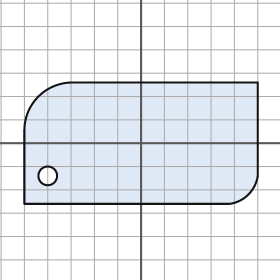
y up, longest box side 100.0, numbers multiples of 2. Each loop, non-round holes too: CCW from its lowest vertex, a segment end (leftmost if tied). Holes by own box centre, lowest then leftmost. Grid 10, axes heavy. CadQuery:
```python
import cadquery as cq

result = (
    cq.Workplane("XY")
    .moveTo(-50.0, -26.0)
    .lineTo(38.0, -26.0)
    .threePointArc((46.0, -22.0), (50.0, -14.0))
    .lineTo(50.0, 26.0)
    .lineTo(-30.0, 26.0)
    .threePointArc((-44.0, 20.0), (-50.0, 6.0))
    .close()
    .moveTo(-40.0, -14.0)
    .circle(4.0)
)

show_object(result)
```